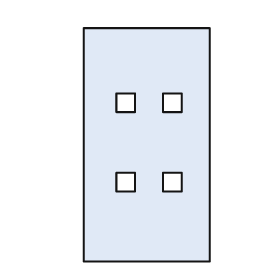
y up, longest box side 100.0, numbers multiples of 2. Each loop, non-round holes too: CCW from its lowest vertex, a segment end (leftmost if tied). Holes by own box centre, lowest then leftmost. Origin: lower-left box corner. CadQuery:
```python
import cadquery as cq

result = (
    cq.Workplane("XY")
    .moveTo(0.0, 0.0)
    .lineTo(54.0, 0.0)
    .lineTo(54.0, 100.0)
    .lineTo(0.0, 100.0)
    .close()
    .moveTo(14.0, 30.0)
    .lineTo(22.0, 30.0)
    .lineTo(22.0, 38.0)
    .lineTo(14.0, 38.0)
    .close()
    .moveTo(34.0, 30.0)
    .lineTo(42.0, 30.0)
    .lineTo(42.0, 38.0)
    .lineTo(34.0, 38.0)
    .close()
    .moveTo(14.0, 64.0)
    .lineTo(22.0, 64.0)
    .lineTo(22.0, 72.0)
    .lineTo(14.0, 72.0)
    .close()
    .moveTo(34.0, 64.0)
    .lineTo(42.0, 64.0)
    .lineTo(42.0, 72.0)
    .lineTo(34.0, 72.0)
    .close()
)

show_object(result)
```